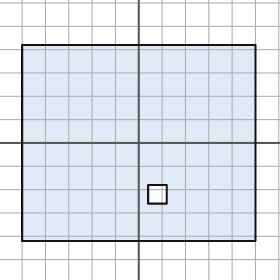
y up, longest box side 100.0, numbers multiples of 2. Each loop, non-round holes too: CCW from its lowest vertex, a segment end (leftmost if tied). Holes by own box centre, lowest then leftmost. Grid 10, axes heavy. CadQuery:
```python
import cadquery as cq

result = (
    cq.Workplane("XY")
    .moveTo(-50.0, -42.0)
    .lineTo(50.0, -42.0)
    .lineTo(50.0, 42.0)
    .lineTo(-50.0, 42.0)
    .close()
    .moveTo(4.0, -26.0)
    .lineTo(12.0, -26.0)
    .lineTo(12.0, -18.0)
    .lineTo(4.0, -18.0)
    .close()
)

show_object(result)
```